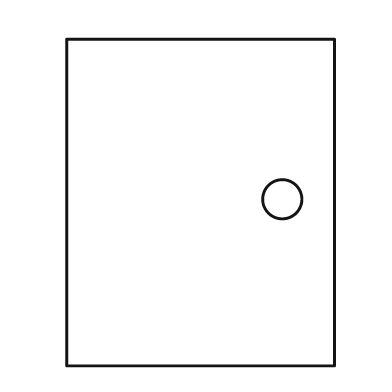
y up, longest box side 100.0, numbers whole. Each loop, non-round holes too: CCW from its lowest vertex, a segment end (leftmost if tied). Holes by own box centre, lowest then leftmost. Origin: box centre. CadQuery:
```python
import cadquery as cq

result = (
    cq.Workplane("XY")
    .moveTo(-41.0, -50.0)
    .lineTo(41.0, -50.0)
    .lineTo(41.0, 50.0)
    .lineTo(-41.0, 50.0)
    .close()
    .moveTo(25.0, 1.0)
    .circle(6.0)
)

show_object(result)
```